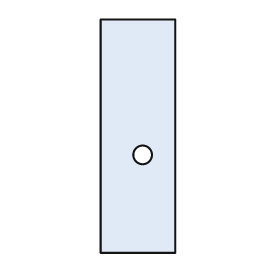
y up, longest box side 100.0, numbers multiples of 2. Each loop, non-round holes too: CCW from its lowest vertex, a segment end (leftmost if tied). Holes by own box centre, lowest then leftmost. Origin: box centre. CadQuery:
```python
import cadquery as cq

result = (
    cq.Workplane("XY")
    .moveTo(-16.0, -50.0)
    .lineTo(16.0, -50.0)
    .lineTo(16.0, 50.0)
    .lineTo(-16.0, 50.0)
    .close()
    .moveTo(2.0, -8.0)
    .circle(4.0)
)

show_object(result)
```